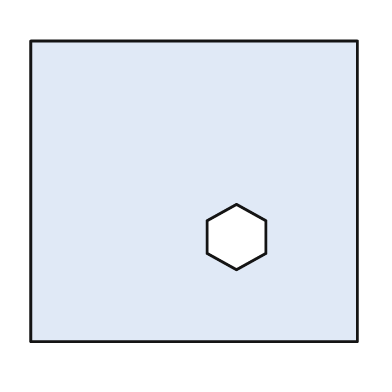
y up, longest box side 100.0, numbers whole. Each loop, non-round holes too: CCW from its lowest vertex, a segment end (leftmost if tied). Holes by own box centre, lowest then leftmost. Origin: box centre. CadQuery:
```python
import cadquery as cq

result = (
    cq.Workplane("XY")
    .moveTo(-50.0, -46.0)
    .lineTo(50.0, -46.0)
    .lineTo(50.0, 46.0)
    .lineTo(-50.0, 46.0)
    .close()
    .moveTo(13.0, -24.0)
    .lineTo(22.0, -19.0)
    .lineTo(22.0, -9.0)
    .lineTo(13.0, -4.0)
    .lineTo(4.0, -9.0)
    .lineTo(4.0, -19.0)
    .close()
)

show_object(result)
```